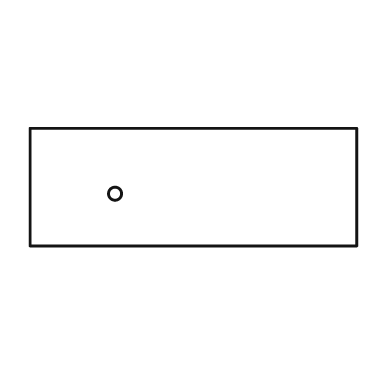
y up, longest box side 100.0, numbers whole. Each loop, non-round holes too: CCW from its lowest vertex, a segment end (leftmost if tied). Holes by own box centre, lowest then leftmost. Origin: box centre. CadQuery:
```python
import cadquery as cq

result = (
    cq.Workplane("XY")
    .moveTo(-50.0, -18.0)
    .lineTo(50.0, -18.0)
    .lineTo(50.0, 18.0)
    .lineTo(-50.0, 18.0)
    .close()
    .moveTo(-24.0, -2.0)
    .circle(2.0)
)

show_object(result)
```